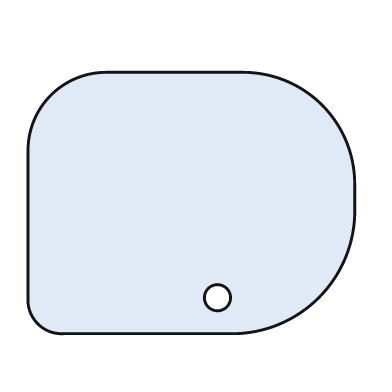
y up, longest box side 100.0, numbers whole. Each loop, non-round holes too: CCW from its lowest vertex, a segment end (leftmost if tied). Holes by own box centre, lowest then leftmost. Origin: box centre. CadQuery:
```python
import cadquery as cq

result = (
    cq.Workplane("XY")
    .moveTo(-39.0, -40.0)
    .lineTo(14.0, -40.0)
    .threePointArc((39.0, -29.0), (50.0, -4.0))
    .lineTo(50.0, 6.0)
    .threePointArc((40.0, 30.0), (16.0, 40.0))
    .lineTo(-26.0, 40.0)
    .threePointArc((-43.0, 33.0), (-50.0, 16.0))
    .lineTo(-50.0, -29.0)
    .threePointArc((-47.0, -37.0), (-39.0, -40.0))
    .close()
    .moveTo(8.0, -29.0)
    .circle(4.0)
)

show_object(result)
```